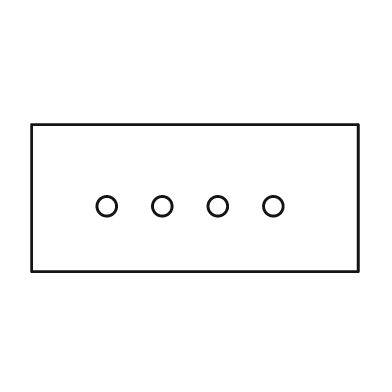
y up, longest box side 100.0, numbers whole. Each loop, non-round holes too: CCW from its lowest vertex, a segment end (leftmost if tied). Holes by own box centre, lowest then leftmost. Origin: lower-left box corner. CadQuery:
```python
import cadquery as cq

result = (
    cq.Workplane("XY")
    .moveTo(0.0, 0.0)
    .lineTo(100.0, 0.0)
    .lineTo(100.0, 45.0)
    .lineTo(0.0, 45.0)
    .close()
    .moveTo(23.0, 20.0)
    .circle(3.0)
    .moveTo(40.0, 20.0)
    .circle(3.0)
    .moveTo(57.0, 20.0)
    .circle(3.0)
    .moveTo(74.0, 20.0)
    .circle(3.0)
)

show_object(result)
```